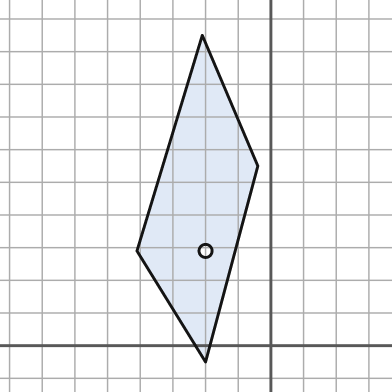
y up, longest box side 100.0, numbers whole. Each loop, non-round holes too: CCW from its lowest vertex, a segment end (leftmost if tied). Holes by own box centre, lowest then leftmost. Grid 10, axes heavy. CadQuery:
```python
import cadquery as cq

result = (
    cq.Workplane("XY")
    .moveTo(-20.0, -5.0)
    .lineTo(-4.0, 55.0)
    .lineTo(-21.0, 95.0)
    .lineTo(-41.0, 29.0)
    .close()
    .moveTo(-20.0, 29.0)
    .circle(2.0)
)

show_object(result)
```